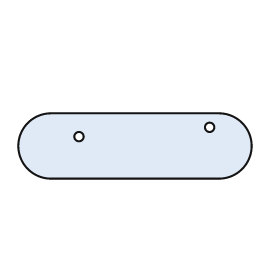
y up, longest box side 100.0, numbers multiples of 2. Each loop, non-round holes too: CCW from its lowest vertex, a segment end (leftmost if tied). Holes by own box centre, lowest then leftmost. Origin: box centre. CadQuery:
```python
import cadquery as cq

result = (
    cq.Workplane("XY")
    .moveTo(-36.0, -14.0)
    .lineTo(36.0, -14.0)
    .threePointArc((50.0, 0.0), (36.0, 14.0))
    .lineTo(-36.0, 14.0)
    .threePointArc((-50.0, 0.0), (-36.0, -14.0))
    .close()
    .moveTo(-24.0, 4.0)
    .circle(2.0)
    .moveTo(32.0, 8.0)
    .circle(2.0)
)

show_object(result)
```